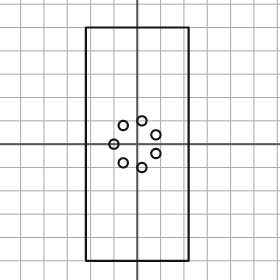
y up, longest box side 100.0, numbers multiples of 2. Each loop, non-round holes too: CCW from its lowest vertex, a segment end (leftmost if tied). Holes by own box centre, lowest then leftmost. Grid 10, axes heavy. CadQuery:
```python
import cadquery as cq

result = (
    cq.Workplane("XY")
    .moveTo(-22.0, -50.0)
    .lineTo(22.0, -50.0)
    .lineTo(22.0, 50.0)
    .lineTo(-22.0, 50.0)
    .close()
    .moveTo(2.0, -10.0)
    .circle(2.0)
    .moveTo(-6.0, -8.0)
    .circle(2.0)
    .moveTo(8.0, -4.0)
    .circle(2.0)
    .moveTo(-10.0, 0.0)
    .circle(2.0)
    .moveTo(8.0, 4.0)
    .circle(2.0)
    .moveTo(-6.0, 8.0)
    .circle(2.0)
    .moveTo(2.0, 10.0)
    .circle(2.0)
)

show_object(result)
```